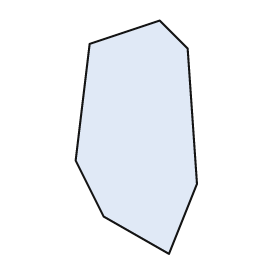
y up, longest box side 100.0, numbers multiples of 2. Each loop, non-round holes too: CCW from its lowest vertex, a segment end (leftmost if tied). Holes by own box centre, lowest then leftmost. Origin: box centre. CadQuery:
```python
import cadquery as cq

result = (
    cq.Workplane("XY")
    .moveTo(14.0, -50.0)
    .lineTo(26.0, -20.0)
    .lineTo(22.0, 38.0)
    .lineTo(10.0, 50.0)
    .lineTo(-20.0, 40.0)
    .lineTo(-26.0, -10.0)
    .lineTo(-14.0, -34.0)
    .close()
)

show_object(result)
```